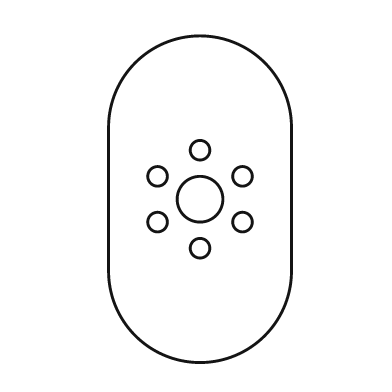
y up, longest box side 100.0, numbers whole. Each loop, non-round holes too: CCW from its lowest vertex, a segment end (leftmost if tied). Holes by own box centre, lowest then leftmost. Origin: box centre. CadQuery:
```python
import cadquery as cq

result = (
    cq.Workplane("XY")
    .moveTo(-28.0, -22.0)
    .threePointArc((0.0, -50.0), (28.0, -22.0))
    .lineTo(28.0, 22.0)
    .threePointArc((0.0, 50.0), (-28.0, 22.0))
    .close()
    .moveTo(0.0, -15.0)
    .circle(3.0)
    .moveTo(-13.0, -7.0)
    .circle(3.0)
    .moveTo(13.0, -7.0)
    .circle(3.0)
    .moveTo(0.0, 0.0)
    .circle(7.0)
    .moveTo(-13.0, 7.0)
    .circle(3.0)
    .moveTo(13.0, 7.0)
    .circle(3.0)
    .moveTo(0.0, 15.0)
    .circle(3.0)
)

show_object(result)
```